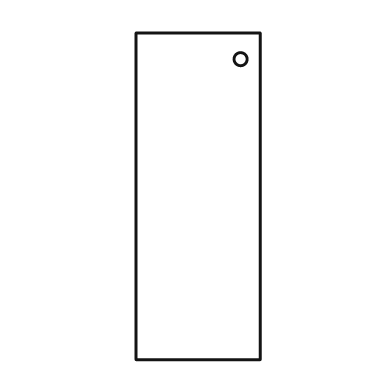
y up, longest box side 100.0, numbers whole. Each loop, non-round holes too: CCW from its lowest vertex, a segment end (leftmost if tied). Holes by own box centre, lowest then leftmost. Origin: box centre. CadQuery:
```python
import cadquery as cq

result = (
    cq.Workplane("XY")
    .moveTo(-19.0, -50.0)
    .lineTo(19.0, -50.0)
    .lineTo(19.0, 50.0)
    .lineTo(-19.0, 50.0)
    .close()
    .moveTo(13.0, 42.0)
    .circle(2.0)
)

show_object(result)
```